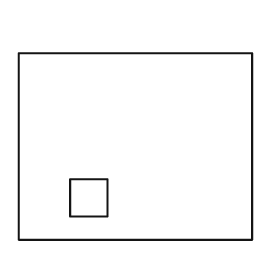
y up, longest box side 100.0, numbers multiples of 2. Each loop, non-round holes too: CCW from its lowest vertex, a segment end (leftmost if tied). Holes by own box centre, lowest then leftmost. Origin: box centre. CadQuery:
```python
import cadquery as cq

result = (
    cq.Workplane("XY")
    .moveTo(-50.0, -40.0)
    .lineTo(50.0, -40.0)
    .lineTo(50.0, 40.0)
    .lineTo(-50.0, 40.0)
    .close()
    .moveTo(-28.0, -30.0)
    .lineTo(-12.0, -30.0)
    .lineTo(-12.0, -14.0)
    .lineTo(-28.0, -14.0)
    .close()
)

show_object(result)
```